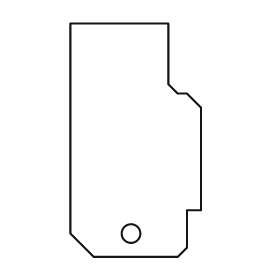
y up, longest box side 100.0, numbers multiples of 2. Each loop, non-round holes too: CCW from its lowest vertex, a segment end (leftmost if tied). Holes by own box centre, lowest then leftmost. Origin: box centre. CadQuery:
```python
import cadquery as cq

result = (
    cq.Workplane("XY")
    .moveTo(-18.0, -50.0)
    .lineTo(18.0, -50.0)
    .lineTo(22.0, -46.0)
    .lineTo(22.0, -30.0)
    .lineTo(28.0, -30.0)
    .lineTo(28.0, 14.0)
    .lineTo(22.0, 20.0)
    .lineTo(18.0, 20.0)
    .lineTo(14.0, 24.0)
    .lineTo(14.0, 50.0)
    .lineTo(-28.0, 50.0)
    .lineTo(-28.0, -40.0)
    .close()
    .moveTo(-2.0, -40.0)
    .circle(4.0)
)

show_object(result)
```